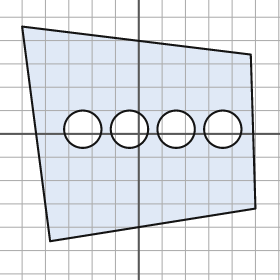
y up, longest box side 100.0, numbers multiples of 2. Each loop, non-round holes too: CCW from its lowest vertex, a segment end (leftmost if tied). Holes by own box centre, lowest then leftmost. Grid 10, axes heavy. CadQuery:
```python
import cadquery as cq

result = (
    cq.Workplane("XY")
    .moveTo(-38.0, -46.0)
    .lineTo(50.0, -32.0)
    .lineTo(48.0, 34.0)
    .lineTo(-50.0, 46.0)
    .close()
    .moveTo(-24.0, 2.0)
    .circle(8.0)
    .moveTo(-4.0, 2.0)
    .circle(8.0)
    .moveTo(16.0, 2.0)
    .circle(8.0)
    .moveTo(36.0, 2.0)
    .circle(8.0)
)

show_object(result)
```